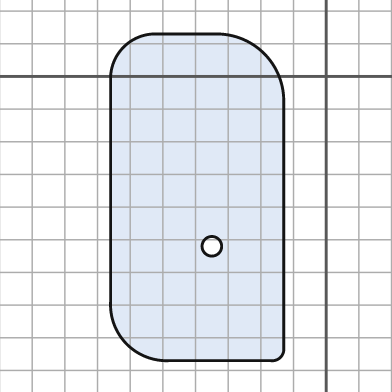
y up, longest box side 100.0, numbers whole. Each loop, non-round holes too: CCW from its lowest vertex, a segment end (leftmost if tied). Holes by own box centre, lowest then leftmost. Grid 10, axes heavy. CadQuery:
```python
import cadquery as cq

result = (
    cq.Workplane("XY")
    .moveTo(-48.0, -87.0)
    .lineTo(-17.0, -87.0)
    .threePointArc((-14.0, -86.0), (-13.0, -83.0))
    .lineTo(-13.0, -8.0)
    .threePointArc((-19.0, 7.0), (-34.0, 13.0))
    .lineTo(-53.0, 13.0)
    .threePointArc((-62.0, 9.0), (-66.0, 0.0))
    .lineTo(-66.0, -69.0)
    .threePointArc((-61.0, -82.0), (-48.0, -87.0))
    .close()
    .moveTo(-35.0, -52.0)
    .circle(3.0)
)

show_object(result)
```